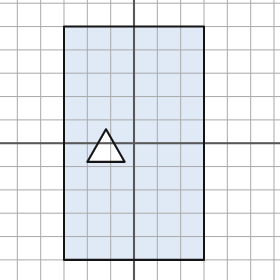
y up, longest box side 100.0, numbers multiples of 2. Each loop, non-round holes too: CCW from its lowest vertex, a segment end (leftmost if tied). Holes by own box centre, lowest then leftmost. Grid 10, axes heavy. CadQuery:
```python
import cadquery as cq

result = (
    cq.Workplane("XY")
    .moveTo(-30.0, -50.0)
    .lineTo(30.0, -50.0)
    .lineTo(30.0, 50.0)
    .lineTo(-30.0, 50.0)
    .close()
    .moveTo(-20.0, -8.0)
    .lineTo(-4.0, -8.0)
    .lineTo(-12.0, 6.0)
    .close()
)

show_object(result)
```